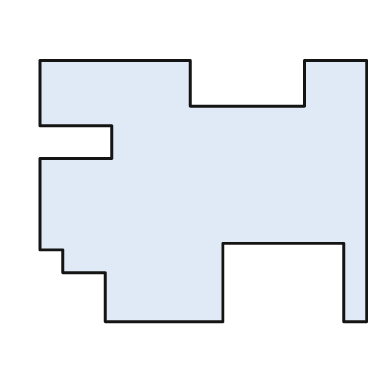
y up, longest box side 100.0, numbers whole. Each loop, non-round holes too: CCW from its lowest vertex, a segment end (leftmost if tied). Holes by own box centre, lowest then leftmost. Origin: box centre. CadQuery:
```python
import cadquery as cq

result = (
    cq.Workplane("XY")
    .moveTo(-30.0, -40.0)
    .lineTo(6.0, -40.0)
    .lineTo(6.0, -16.0)
    .lineTo(43.0, -16.0)
    .lineTo(43.0, -40.0)
    .lineTo(50.0, -40.0)
    .lineTo(50.0, 40.0)
    .lineTo(31.0, 40.0)
    .lineTo(31.0, 26.0)
    .lineTo(-4.0, 26.0)
    .lineTo(-4.0, 40.0)
    .lineTo(-50.0, 40.0)
    .lineTo(-50.0, 20.0)
    .lineTo(-28.0, 20.0)
    .lineTo(-28.0, 10.0)
    .lineTo(-50.0, 10.0)
    .lineTo(-50.0, -18.0)
    .lineTo(-43.0, -18.0)
    .lineTo(-43.0, -25.0)
    .lineTo(-30.0, -25.0)
    .close()
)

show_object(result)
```